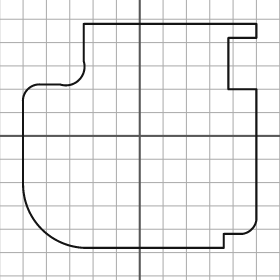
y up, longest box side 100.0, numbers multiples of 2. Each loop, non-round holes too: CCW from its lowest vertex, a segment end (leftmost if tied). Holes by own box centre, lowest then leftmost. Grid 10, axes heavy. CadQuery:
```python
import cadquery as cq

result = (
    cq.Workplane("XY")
    .moveTo(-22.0, -48.0)
    .lineTo(36.0, -48.0)
    .lineTo(36.0, -42.0)
    .lineTo(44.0, -42.0)
    .threePointArc((48.0, -40.0), (50.0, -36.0))
    .lineTo(50.0, 20.0)
    .lineTo(38.0, 20.0)
    .lineTo(38.0, 42.0)
    .lineTo(50.0, 42.0)
    .lineTo(50.0, 48.0)
    .lineTo(-24.0, 48.0)
    .lineTo(-24.0, 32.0)
    .threePointArc((-26.0, 24.0), (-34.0, 22.0))
    .lineTo(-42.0, 22.0)
    .threePointArc((-48.0, 20.0), (-50.0, 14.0))
    .lineTo(-50.0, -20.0)
    .threePointArc((-42.0, -40.0), (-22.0, -48.0))
    .close()
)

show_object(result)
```